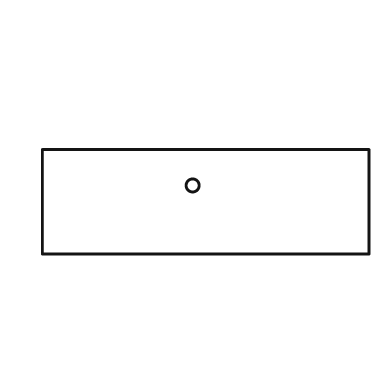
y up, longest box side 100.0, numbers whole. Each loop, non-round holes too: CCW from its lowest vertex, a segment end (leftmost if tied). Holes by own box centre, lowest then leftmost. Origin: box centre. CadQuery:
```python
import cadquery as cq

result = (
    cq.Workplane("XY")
    .moveTo(-50.0, -16.0)
    .lineTo(50.0, -16.0)
    .lineTo(50.0, 16.0)
    .lineTo(-50.0, 16.0)
    .close()
    .moveTo(-4.0, 5.0)
    .circle(2.0)
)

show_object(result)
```